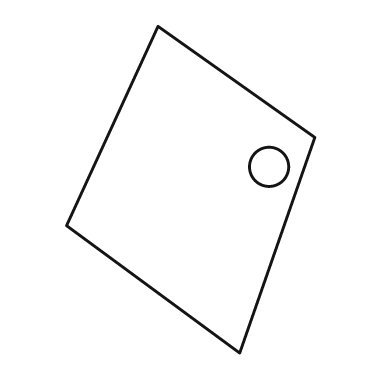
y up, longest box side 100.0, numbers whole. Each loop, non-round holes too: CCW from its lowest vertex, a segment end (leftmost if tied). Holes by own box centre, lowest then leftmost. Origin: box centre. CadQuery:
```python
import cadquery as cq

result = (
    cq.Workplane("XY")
    .moveTo(15.0, -50.0)
    .lineTo(38.0, 16.0)
    .lineTo(-10.0, 50.0)
    .lineTo(-38.0, -11.0)
    .close()
    .moveTo(24.0, 7.0)
    .circle(6.0)
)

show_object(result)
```